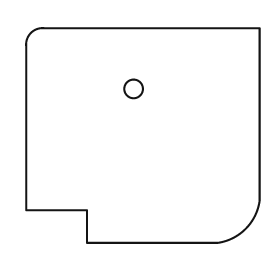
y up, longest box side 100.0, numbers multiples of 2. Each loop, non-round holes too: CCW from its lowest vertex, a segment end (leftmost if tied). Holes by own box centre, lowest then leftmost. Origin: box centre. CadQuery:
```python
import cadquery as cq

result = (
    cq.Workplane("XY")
    .moveTo(-24.0, -46.0)
    .lineTo(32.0, -46.0)
    .threePointArc((44.0, -40.0), (50.0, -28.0))
    .lineTo(50.0, 46.0)
    .lineTo(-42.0, 46.0)
    .threePointArc((-48.0, 44.0), (-50.0, 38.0))
    .lineTo(-50.0, -32.0)
    .lineTo(-24.0, -32.0)
    .close()
    .moveTo(-4.0, 20.0)
    .circle(4.0)
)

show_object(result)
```